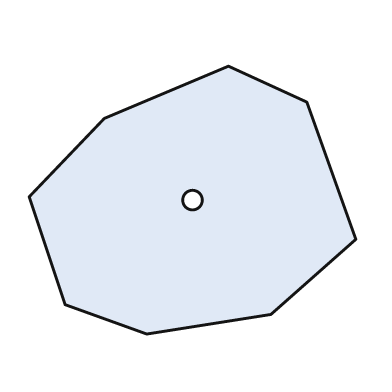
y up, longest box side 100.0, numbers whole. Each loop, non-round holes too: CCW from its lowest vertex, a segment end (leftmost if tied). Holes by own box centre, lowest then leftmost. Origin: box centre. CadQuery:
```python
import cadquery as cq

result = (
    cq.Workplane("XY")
    .moveTo(-14.0, -41.0)
    .lineTo(24.0, -35.0)
    .lineTo(50.0, -12.0)
    .lineTo(35.0, 30.0)
    .lineTo(11.0, 41.0)
    .lineTo(-27.0, 25.0)
    .lineTo(-50.0, 1.0)
    .lineTo(-39.0, -32.0)
    .close()
    .moveTo(0.0, 0.0)
    .circle(3.0)
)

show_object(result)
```